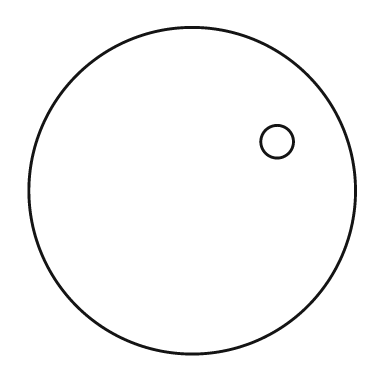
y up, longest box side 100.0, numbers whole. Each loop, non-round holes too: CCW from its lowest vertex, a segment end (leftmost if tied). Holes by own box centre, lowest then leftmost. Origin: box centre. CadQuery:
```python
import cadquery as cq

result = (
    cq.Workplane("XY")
    .moveTo(0.0, 0.0)
    .circle(50.0)
    .moveTo(26.0, 15.0)
    .circle(5.0)
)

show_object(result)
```